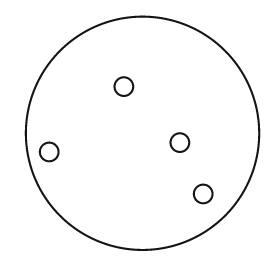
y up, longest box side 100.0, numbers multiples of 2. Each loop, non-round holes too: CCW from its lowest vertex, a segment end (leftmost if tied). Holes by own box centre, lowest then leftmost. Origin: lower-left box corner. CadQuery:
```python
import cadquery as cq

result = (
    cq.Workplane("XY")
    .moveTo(50.0, 50.0)
    .circle(50.0)
    .moveTo(76.0, 24.0)
    .circle(4.0)
    .moveTo(10.0, 42.0)
    .circle(4.0)
    .moveTo(66.0, 46.0)
    .circle(4.0)
    .moveTo(42.0, 70.0)
    .circle(4.0)
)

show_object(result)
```